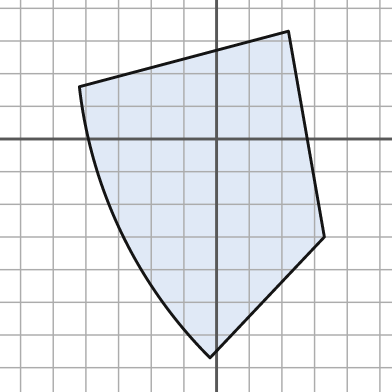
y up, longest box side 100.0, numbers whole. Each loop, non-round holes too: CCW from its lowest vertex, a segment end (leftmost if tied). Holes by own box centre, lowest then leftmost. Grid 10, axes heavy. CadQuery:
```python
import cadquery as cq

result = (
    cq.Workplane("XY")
    .moveTo(-2.0, -67.0)
    .lineTo(33.0, -30.0)
    .lineTo(22.0, 33.0)
    .lineTo(-42.0, 16.0)
    .threePointArc((-29.0, -29.0), (-2.0, -67.0))
    .close()
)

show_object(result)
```